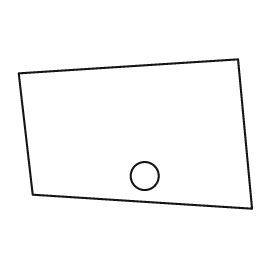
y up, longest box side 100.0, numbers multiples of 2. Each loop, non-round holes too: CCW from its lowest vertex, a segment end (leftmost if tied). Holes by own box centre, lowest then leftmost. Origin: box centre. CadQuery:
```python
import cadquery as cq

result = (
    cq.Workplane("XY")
    .moveTo(50.0, -32.0)
    .lineTo(44.0, 32.0)
    .lineTo(-50.0, 26.0)
    .lineTo(-44.0, -26.0)
    .close()
    .moveTo(4.0, -18.0)
    .circle(6.0)
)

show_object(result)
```